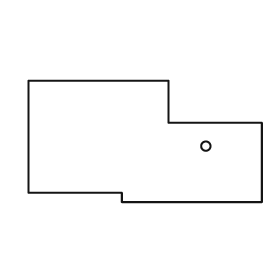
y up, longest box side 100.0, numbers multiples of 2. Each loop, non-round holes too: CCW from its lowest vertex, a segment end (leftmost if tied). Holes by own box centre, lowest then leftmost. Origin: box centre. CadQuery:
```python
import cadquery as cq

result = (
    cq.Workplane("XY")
    .moveTo(-10.0, -26.0)
    .lineTo(50.0, -26.0)
    .lineTo(50.0, 8.0)
    .lineTo(10.0, 8.0)
    .lineTo(10.0, 26.0)
    .lineTo(-50.0, 26.0)
    .lineTo(-50.0, -22.0)
    .lineTo(-10.0, -22.0)
    .close()
    .moveTo(26.0, -2.0)
    .circle(2.0)
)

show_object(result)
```